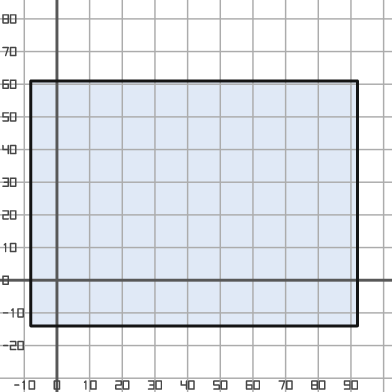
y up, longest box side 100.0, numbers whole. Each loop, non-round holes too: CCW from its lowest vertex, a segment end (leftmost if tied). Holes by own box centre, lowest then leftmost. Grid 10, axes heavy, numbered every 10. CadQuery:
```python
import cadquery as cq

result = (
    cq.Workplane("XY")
    .moveTo(-8.0, -14.0)
    .lineTo(92.0, -14.0)
    .lineTo(92.0, 61.0)
    .lineTo(-8.0, 61.0)
    .close()
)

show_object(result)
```